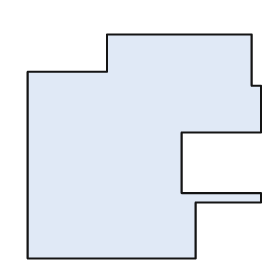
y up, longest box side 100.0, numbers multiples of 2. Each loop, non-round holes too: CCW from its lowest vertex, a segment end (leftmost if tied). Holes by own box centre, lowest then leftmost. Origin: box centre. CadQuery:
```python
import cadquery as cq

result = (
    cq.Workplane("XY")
    .moveTo(-50.0, -48.0)
    .lineTo(22.0, -48.0)
    .lineTo(22.0, -24.0)
    .lineTo(50.0, -24.0)
    .lineTo(50.0, -20.0)
    .lineTo(16.0, -20.0)
    .lineTo(16.0, 6.0)
    .lineTo(50.0, 6.0)
    .lineTo(50.0, 26.0)
    .lineTo(46.0, 26.0)
    .lineTo(46.0, 48.0)
    .lineTo(-16.0, 48.0)
    .lineTo(-16.0, 32.0)
    .lineTo(-50.0, 32.0)
    .close()
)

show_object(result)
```